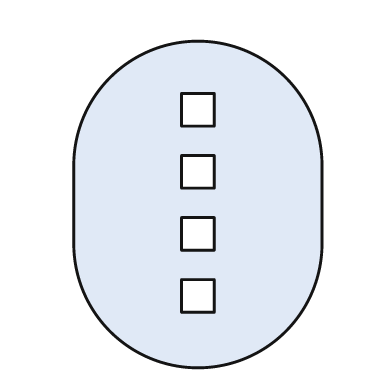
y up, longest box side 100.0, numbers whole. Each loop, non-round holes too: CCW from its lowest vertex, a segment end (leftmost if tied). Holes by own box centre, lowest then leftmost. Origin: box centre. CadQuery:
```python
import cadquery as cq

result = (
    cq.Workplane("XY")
    .moveTo(-38.0, -12.0)
    .threePointArc((0.0, -50.0), (38.0, -12.0))
    .lineTo(38.0, 12.0)
    .threePointArc((0.0, 50.0), (-38.0, 12.0))
    .close()
    .moveTo(-5.0, -33.0)
    .lineTo(5.0, -33.0)
    .lineTo(5.0, -23.0)
    .lineTo(-5.0, -23.0)
    .close()
    .moveTo(-5.0, -14.0)
    .lineTo(5.0, -14.0)
    .lineTo(5.0, -4.0)
    .lineTo(-5.0, -4.0)
    .close()
    .moveTo(-5.0, 5.0)
    .lineTo(5.0, 5.0)
    .lineTo(5.0, 15.0)
    .lineTo(-5.0, 15.0)
    .close()
    .moveTo(-5.0, 24.0)
    .lineTo(5.0, 24.0)
    .lineTo(5.0, 34.0)
    .lineTo(-5.0, 34.0)
    .close()
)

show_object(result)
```